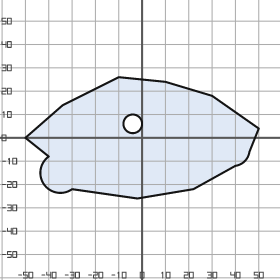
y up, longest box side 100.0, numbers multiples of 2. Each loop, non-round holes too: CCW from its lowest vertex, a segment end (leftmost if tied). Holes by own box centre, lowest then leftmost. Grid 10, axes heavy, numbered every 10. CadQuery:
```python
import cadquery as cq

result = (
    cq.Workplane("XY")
    .moveTo(-2.0, -26.0)
    .lineTo(22.0, -22.0)
    .lineTo(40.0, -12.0)
    .threePointArc((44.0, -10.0), (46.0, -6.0))
    .lineTo(50.0, 4.0)
    .lineTo(30.0, 18.0)
    .lineTo(10.0, 24.0)
    .lineTo(-10.0, 26.0)
    .lineTo(-34.0, 14.0)
    .lineTo(-50.0, 0.0)
    .lineTo(-40.0, -8.0)
    .threePointArc((-42.0, -20.0), (-30.0, -22.0))
    .close()
    .moveTo(-4.0, 6.0)
    .circle(4.0)
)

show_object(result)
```